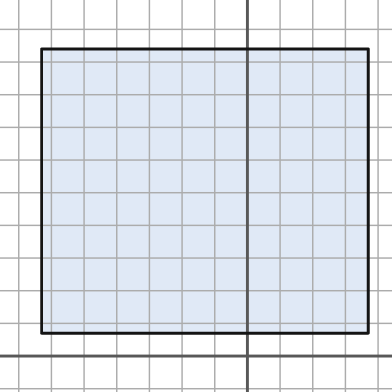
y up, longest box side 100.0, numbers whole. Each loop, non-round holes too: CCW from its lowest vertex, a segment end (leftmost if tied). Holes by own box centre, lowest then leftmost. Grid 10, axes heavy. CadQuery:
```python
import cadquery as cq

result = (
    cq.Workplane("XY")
    .moveTo(-63.0, 7.0)
    .lineTo(37.0, 7.0)
    .lineTo(37.0, 94.0)
    .lineTo(-63.0, 94.0)
    .close()
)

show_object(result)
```